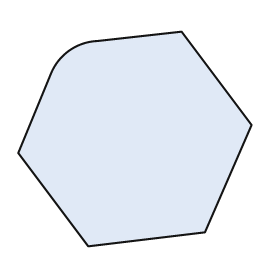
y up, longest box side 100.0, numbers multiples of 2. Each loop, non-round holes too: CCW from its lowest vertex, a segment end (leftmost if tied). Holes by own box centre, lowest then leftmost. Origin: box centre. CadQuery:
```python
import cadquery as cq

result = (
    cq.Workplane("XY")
    .moveTo(-20.0, -46.0)
    .lineTo(30.0, -40.0)
    .lineTo(50.0, 6.0)
    .lineTo(20.0, 46.0)
    .lineTo(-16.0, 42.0)
    .threePointArc((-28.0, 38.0), (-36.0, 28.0))
    .lineTo(-50.0, -6.0)
    .close()
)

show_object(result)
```